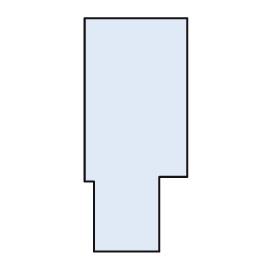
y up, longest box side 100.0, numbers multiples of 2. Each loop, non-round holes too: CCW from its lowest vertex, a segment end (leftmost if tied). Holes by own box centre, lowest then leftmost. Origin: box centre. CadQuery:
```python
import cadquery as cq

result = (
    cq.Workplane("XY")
    .moveTo(-18.0, -50.0)
    .lineTo(10.0, -50.0)
    .lineTo(10.0, -18.0)
    .lineTo(22.0, -18.0)
    .lineTo(22.0, 50.0)
    .lineTo(-22.0, 50.0)
    .lineTo(-22.0, -20.0)
    .lineTo(-18.0, -20.0)
    .close()
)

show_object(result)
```